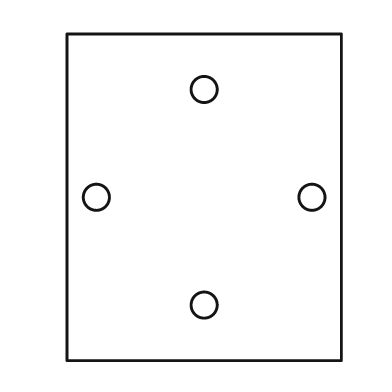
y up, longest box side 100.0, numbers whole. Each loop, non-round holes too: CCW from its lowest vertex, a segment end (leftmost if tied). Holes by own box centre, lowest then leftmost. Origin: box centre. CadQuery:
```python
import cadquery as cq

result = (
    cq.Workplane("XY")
    .moveTo(-42.0, -50.0)
    .lineTo(42.0, -50.0)
    .lineTo(42.0, 50.0)
    .lineTo(-42.0, 50.0)
    .close()
    .moveTo(0.0, -33.0)
    .circle(4.0)
    .moveTo(-33.0, 0.0)
    .circle(4.0)
    .moveTo(33.0, 0.0)
    .circle(4.0)
    .moveTo(0.0, 33.0)
    .circle(4.0)
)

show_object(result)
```